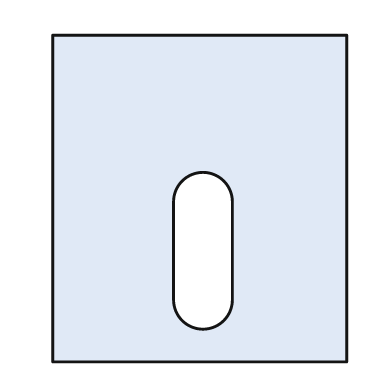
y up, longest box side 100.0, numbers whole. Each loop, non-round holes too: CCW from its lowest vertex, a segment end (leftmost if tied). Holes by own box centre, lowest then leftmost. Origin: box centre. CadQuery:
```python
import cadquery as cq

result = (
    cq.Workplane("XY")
    .moveTo(-45.0, -50.0)
    .lineTo(45.0, -50.0)
    .lineTo(45.0, 50.0)
    .lineTo(-45.0, 50.0)
    .close()
    .moveTo(-8.0, -31.0)
    .threePointArc((1.0, -40.0), (10.0, -31.0))
    .lineTo(10.0, -1.0)
    .threePointArc((1.0, 8.0), (-8.0, -1.0))
    .close()
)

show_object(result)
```